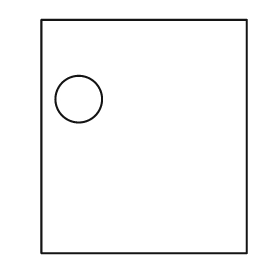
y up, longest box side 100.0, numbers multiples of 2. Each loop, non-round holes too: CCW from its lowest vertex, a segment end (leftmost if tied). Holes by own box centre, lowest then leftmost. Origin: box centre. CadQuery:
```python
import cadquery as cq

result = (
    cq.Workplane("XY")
    .moveTo(-44.0, -50.0)
    .lineTo(44.0, -50.0)
    .lineTo(44.0, 50.0)
    .lineTo(-44.0, 50.0)
    .close()
    .moveTo(-28.0, 16.0)
    .circle(10.0)
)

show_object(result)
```